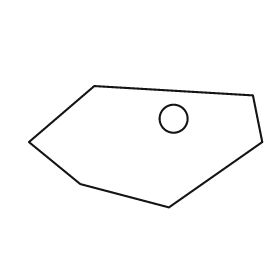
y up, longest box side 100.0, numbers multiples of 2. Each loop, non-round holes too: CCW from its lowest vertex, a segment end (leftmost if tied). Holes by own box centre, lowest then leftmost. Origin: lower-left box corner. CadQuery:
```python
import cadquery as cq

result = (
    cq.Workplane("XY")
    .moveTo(60.0, 0.0)
    .lineTo(100.0, 28.0)
    .lineTo(96.0, 48.0)
    .lineTo(28.0, 52.0)
    .lineTo(0.0, 28.0)
    .lineTo(22.0, 10.0)
    .close()
    .moveTo(62.0, 38.0)
    .circle(6.0)
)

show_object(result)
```